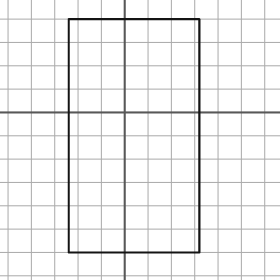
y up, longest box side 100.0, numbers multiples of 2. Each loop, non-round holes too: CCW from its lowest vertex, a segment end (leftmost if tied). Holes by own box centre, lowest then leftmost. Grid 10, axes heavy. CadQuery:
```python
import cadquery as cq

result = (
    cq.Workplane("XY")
    .moveTo(-24.0, -60.0)
    .lineTo(32.0, -60.0)
    .lineTo(32.0, 40.0)
    .lineTo(-24.0, 40.0)
    .close()
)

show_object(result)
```